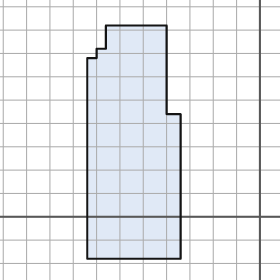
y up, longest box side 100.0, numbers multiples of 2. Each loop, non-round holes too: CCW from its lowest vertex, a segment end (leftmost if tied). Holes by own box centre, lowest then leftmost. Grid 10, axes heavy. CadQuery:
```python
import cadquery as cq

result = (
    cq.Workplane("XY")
    .moveTo(-74.0, -18.0)
    .lineTo(-34.0, -18.0)
    .lineTo(-34.0, 44.0)
    .lineTo(-40.0, 44.0)
    .lineTo(-40.0, 82.0)
    .lineTo(-66.0, 82.0)
    .lineTo(-66.0, 72.0)
    .lineTo(-70.0, 72.0)
    .lineTo(-70.0, 68.0)
    .lineTo(-74.0, 68.0)
    .close()
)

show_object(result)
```